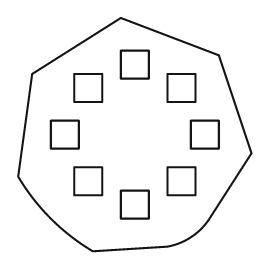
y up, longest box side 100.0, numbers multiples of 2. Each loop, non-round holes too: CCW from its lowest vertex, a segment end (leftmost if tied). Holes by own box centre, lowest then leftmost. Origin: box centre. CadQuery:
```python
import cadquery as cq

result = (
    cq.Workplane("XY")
    .moveTo(-18.0, -50.0)
    .lineTo(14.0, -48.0)
    .threePointArc((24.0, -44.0), (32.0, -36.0))
    .lineTo(50.0, -8.0)
    .lineTo(36.0, 34.0)
    .lineTo(-6.0, 50.0)
    .lineTo(-44.0, 26.0)
    .lineTo(-50.0, -18.0)
    .threePointArc((-36.0, -36.0), (-18.0, -50.0))
    .close()
    .moveTo(-6.0, -36.0)
    .lineTo(6.0, -36.0)
    .lineTo(6.0, -24.0)
    .lineTo(-6.0, -24.0)
    .close()
    .moveTo(-26.0, -26.0)
    .lineTo(-14.0, -26.0)
    .lineTo(-14.0, -14.0)
    .lineTo(-26.0, -14.0)
    .close()
    .moveTo(14.0, -26.0)
    .lineTo(26.0, -26.0)
    .lineTo(26.0, -14.0)
    .lineTo(14.0, -14.0)
    .close()
    .moveTo(-36.0, -6.0)
    .lineTo(-24.0, -6.0)
    .lineTo(-24.0, 6.0)
    .lineTo(-36.0, 6.0)
    .close()
    .moveTo(24.0, -6.0)
    .lineTo(36.0, -6.0)
    .lineTo(36.0, 6.0)
    .lineTo(24.0, 6.0)
    .close()
    .moveTo(-26.0, 14.0)
    .lineTo(-14.0, 14.0)
    .lineTo(-14.0, 26.0)
    .lineTo(-26.0, 26.0)
    .close()
    .moveTo(14.0, 14.0)
    .lineTo(26.0, 14.0)
    .lineTo(26.0, 26.0)
    .lineTo(14.0, 26.0)
    .close()
    .moveTo(-6.0, 24.0)
    .lineTo(6.0, 24.0)
    .lineTo(6.0, 36.0)
    .lineTo(-6.0, 36.0)
    .close()
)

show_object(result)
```